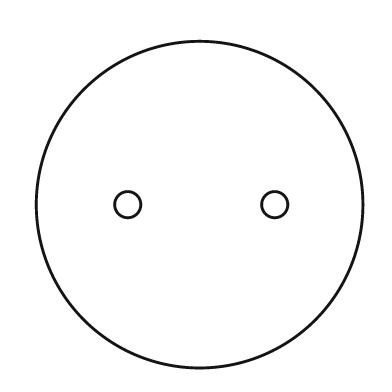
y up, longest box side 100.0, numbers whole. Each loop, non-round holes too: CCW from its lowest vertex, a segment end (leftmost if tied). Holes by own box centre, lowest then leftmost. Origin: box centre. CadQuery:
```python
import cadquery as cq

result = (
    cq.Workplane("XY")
    .moveTo(0.0, 0.0)
    .circle(50.0)
    .moveTo(-22.0, 0.0)
    .circle(4.0)
    .moveTo(23.0, 0.0)
    .circle(4.0)
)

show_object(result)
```